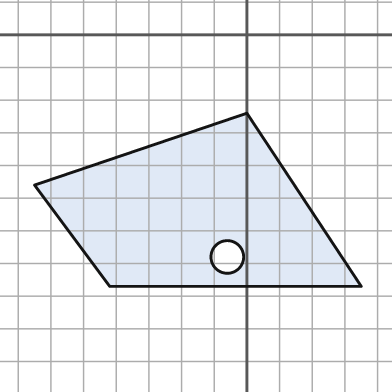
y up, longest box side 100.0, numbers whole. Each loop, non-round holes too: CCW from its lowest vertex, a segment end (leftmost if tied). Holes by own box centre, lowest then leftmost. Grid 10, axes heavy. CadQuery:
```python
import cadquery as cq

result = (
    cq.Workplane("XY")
    .moveTo(-42.0, -77.0)
    .lineTo(35.0, -77.0)
    .lineTo(0.0, -24.0)
    .lineTo(-65.0, -46.0)
    .close()
    .moveTo(-6.0, -68.0)
    .circle(5.0)
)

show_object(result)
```